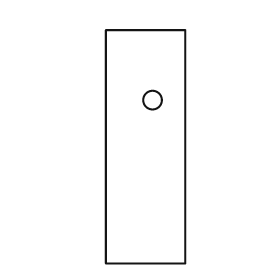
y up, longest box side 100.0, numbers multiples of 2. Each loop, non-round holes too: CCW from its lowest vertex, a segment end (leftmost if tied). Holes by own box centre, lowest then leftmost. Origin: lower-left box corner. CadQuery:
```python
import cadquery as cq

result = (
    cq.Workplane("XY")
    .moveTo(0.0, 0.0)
    .lineTo(34.0, 0.0)
    .lineTo(34.0, 100.0)
    .lineTo(0.0, 100.0)
    .close()
    .moveTo(20.0, 70.0)
    .circle(4.0)
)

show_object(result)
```